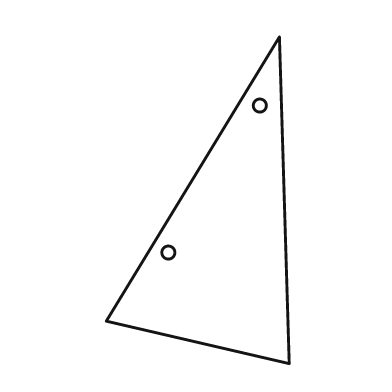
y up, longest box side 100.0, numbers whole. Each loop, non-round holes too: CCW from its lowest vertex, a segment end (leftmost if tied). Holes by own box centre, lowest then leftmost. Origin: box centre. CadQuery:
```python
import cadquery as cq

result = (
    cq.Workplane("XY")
    .moveTo(28.0, -50.0)
    .lineTo(25.0, 50.0)
    .lineTo(-28.0, -37.0)
    .close()
    .moveTo(-9.0, -16.0)
    .circle(2.0)
    .moveTo(19.0, 29.0)
    .circle(2.0)
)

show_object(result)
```